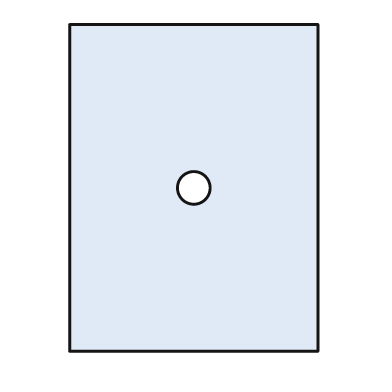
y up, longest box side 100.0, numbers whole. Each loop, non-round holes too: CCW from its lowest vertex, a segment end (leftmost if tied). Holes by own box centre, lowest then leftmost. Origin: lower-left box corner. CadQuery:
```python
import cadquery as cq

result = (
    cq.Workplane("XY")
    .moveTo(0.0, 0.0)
    .lineTo(76.0, 0.0)
    .lineTo(76.0, 100.0)
    .lineTo(0.0, 100.0)
    .close()
    .moveTo(38.0, 50.0)
    .circle(5.0)
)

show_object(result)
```